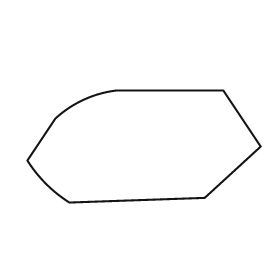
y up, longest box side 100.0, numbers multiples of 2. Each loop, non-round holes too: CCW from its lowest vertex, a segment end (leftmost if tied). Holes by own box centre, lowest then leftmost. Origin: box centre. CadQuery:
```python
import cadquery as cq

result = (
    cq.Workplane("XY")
    .moveTo(-32.0, -24.0)
    .lineTo(26.0, -22.0)
    .lineTo(50.0, 0.0)
    .lineTo(34.0, 24.0)
    .lineTo(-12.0, 24.0)
    .threePointArc((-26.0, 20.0), (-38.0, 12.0))
    .lineTo(-50.0, -6.0)
    .threePointArc((-42.0, -16.0), (-32.0, -24.0))
    .close()
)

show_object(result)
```